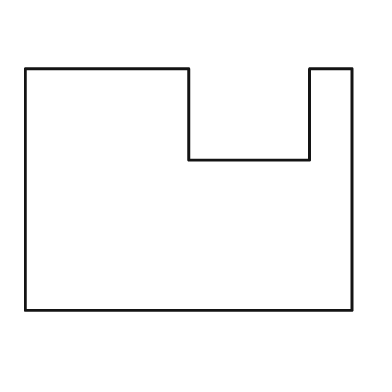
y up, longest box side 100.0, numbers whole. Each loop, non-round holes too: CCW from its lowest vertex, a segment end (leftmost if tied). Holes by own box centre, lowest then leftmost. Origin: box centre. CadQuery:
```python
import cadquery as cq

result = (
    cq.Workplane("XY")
    .moveTo(-50.0, -37.0)
    .lineTo(50.0, -37.0)
    .lineTo(50.0, 37.0)
    .lineTo(37.0, 37.0)
    .lineTo(37.0, 9.0)
    .lineTo(0.0, 9.0)
    .lineTo(0.0, 37.0)
    .lineTo(-50.0, 37.0)
    .close()
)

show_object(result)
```